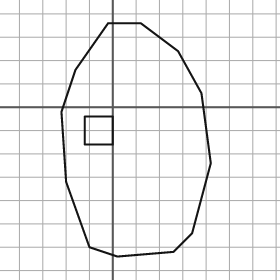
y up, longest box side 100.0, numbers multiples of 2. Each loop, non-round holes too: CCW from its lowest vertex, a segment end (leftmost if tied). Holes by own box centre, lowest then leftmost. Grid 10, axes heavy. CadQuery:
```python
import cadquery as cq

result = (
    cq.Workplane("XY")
    .moveTo(2.0, -64.0)
    .lineTo(26.0, -62.0)
    .lineTo(34.0, -54.0)
    .lineTo(42.0, -24.0)
    .lineTo(38.0, 6.0)
    .lineTo(28.0, 24.0)
    .lineTo(12.0, 36.0)
    .lineTo(-2.0, 36.0)
    .lineTo(-16.0, 16.0)
    .lineTo(-22.0, -2.0)
    .lineTo(-20.0, -32.0)
    .lineTo(-10.0, -60.0)
    .close()
    .moveTo(-12.0, -16.0)
    .lineTo(0.0, -16.0)
    .lineTo(0.0, -4.0)
    .lineTo(-12.0, -4.0)
    .close()
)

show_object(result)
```